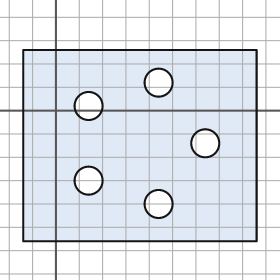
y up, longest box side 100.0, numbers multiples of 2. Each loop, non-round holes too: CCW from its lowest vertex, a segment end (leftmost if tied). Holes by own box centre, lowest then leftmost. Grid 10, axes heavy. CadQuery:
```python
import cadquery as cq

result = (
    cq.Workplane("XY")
    .moveTo(-14.0, -56.0)
    .lineTo(86.0, -56.0)
    .lineTo(86.0, 26.0)
    .lineTo(-14.0, 26.0)
    .close()
    .moveTo(44.0, -40.0)
    .circle(6.0)
    .moveTo(14.0, -30.0)
    .circle(6.0)
    .moveTo(64.0, -14.0)
    .circle(6.0)
    .moveTo(14.0, 2.0)
    .circle(6.0)
    .moveTo(44.0, 12.0)
    .circle(6.0)
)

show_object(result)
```